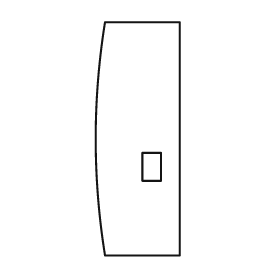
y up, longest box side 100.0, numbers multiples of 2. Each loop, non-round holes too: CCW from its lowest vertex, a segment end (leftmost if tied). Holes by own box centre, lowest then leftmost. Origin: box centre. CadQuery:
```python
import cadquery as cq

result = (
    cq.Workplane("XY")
    .moveTo(-14.0, -50.0)
    .lineTo(18.0, -50.0)
    .lineTo(18.0, 50.0)
    .lineTo(-14.0, 50.0)
    .threePointArc((-18.0, 0.0), (-14.0, -50.0))
    .close()
    .moveTo(2.0, -18.0)
    .lineTo(10.0, -18.0)
    .lineTo(10.0, -6.0)
    .lineTo(2.0, -6.0)
    .close()
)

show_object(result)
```